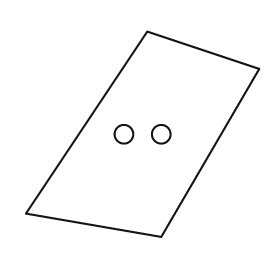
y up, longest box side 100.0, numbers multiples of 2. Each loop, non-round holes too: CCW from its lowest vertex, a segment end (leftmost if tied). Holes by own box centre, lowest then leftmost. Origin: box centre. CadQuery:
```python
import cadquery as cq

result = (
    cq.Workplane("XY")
    .moveTo(8.0, -44.0)
    .lineTo(50.0, 28.0)
    .lineTo(2.0, 44.0)
    .lineTo(-50.0, -34.0)
    .close()
    .moveTo(-8.0, 0.0)
    .circle(4.0)
    .moveTo(8.0, 0.0)
    .circle(4.0)
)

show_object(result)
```